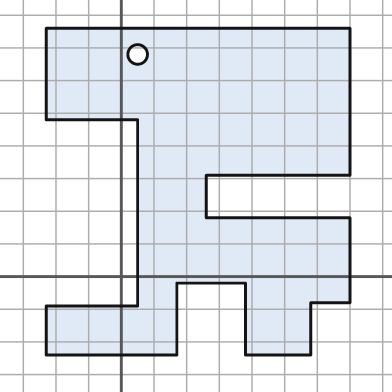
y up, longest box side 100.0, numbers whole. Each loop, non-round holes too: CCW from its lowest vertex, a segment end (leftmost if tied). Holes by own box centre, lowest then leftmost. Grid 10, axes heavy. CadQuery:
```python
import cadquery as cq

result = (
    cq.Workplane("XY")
    .moveTo(-23.0, -24.0)
    .lineTo(17.0, -24.0)
    .lineTo(17.0, -2.0)
    .lineTo(38.0, -2.0)
    .lineTo(38.0, -24.0)
    .lineTo(58.0, -24.0)
    .lineTo(58.0, -8.0)
    .lineTo(70.0, -8.0)
    .lineTo(70.0, 18.0)
    .lineTo(26.0, 18.0)
    .lineTo(26.0, 31.0)
    .lineTo(70.0, 31.0)
    .lineTo(70.0, 76.0)
    .lineTo(-23.0, 76.0)
    .lineTo(-23.0, 48.0)
    .lineTo(5.0, 48.0)
    .lineTo(5.0, -9.0)
    .lineTo(-23.0, -9.0)
    .close()
    .moveTo(5.0, 68.0)
    .circle(3.0)
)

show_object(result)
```